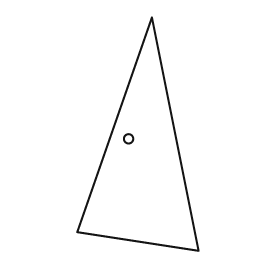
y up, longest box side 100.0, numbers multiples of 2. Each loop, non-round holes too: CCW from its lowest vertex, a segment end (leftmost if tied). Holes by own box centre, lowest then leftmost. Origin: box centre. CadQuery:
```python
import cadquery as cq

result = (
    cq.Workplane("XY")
    .moveTo(26.0, -50.0)
    .lineTo(6.0, 50.0)
    .lineTo(-26.0, -42.0)
    .close()
    .moveTo(-4.0, -2.0)
    .circle(2.0)
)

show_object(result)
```